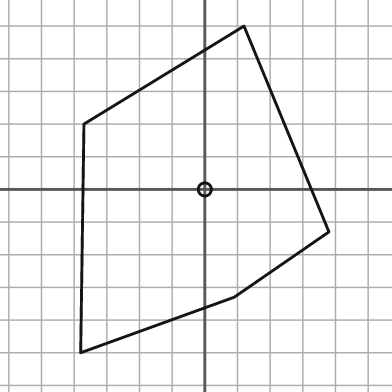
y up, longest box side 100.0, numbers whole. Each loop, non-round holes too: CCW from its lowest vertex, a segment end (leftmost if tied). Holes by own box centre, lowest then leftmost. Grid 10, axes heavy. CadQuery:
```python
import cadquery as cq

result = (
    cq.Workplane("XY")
    .moveTo(-38.0, -50.0)
    .lineTo(9.0, -33.0)
    .lineTo(38.0, -13.0)
    .lineTo(12.0, 50.0)
    .lineTo(-37.0, 20.0)
    .close()
    .moveTo(0.0, 0.0)
    .circle(2.0)
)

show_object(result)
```